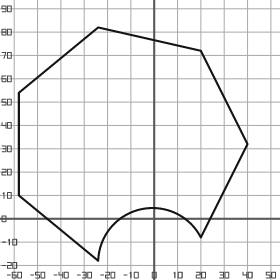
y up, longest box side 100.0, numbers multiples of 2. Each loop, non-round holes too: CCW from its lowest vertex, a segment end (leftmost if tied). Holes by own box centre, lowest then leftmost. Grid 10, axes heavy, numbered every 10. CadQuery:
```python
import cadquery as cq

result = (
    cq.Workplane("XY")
    .moveTo(-24.0, -18.0)
    .threePointArc((-6.0, 4.0), (20.0, -8.0))
    .lineTo(40.0, 32.0)
    .lineTo(20.0, 72.0)
    .lineTo(-24.0, 82.0)
    .lineTo(-58.0, 54.0)
    .lineTo(-58.0, 10.0)
    .close()
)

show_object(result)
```